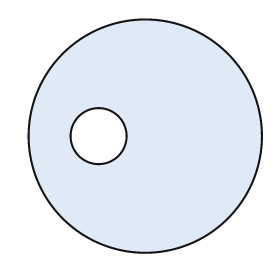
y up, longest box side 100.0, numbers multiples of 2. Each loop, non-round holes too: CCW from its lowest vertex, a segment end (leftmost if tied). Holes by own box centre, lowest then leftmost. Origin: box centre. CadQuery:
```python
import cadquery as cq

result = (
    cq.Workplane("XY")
    .moveTo(0.0, 0.0)
    .circle(50.0)
    .moveTo(-20.0, 0.0)
    .circle(12.0)
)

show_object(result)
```